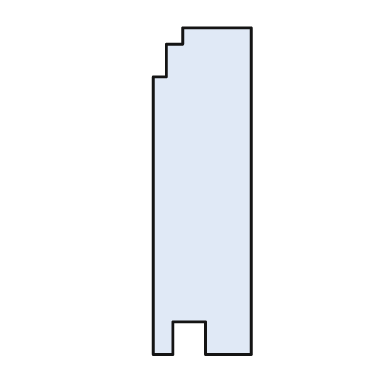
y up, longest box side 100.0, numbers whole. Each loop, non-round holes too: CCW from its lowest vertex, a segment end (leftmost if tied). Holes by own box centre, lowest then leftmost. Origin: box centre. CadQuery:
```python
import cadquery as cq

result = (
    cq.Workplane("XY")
    .moveTo(-15.0, -50.0)
    .lineTo(-9.0, -50.0)
    .lineTo(-9.0, -40.0)
    .lineTo(1.0, -40.0)
    .lineTo(1.0, -50.0)
    .lineTo(15.0, -50.0)
    .lineTo(15.0, 50.0)
    .lineTo(-6.0, 50.0)
    .lineTo(-6.0, 45.0)
    .lineTo(-11.0, 45.0)
    .lineTo(-11.0, 35.0)
    .lineTo(-15.0, 35.0)
    .close()
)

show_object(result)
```